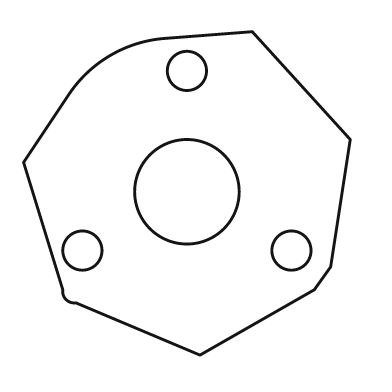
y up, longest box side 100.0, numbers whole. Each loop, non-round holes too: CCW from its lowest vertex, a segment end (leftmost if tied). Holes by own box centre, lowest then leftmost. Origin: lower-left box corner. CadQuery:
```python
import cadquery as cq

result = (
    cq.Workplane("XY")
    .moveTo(54.0, 0.0)
    .lineTo(89.0, 20.0)
    .lineTo(94.0, 27.0)
    .lineTo(100.0, 66.0)
    .lineTo(70.0, 99.0)
    .lineTo(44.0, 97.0)
    .threePointArc((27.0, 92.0), (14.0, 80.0))
    .lineTo(0.0, 59.0)
    .lineTo(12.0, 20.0)
    .threePointArc((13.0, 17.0), (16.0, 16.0))
    .close()
    .moveTo(18.0, 32.0)
    .circle(6.0)
    .moveTo(82.0, 32.0)
    .circle(6.0)
    .moveTo(50.0, 50.0)
    .circle(16.0)
    .moveTo(50.0, 87.0)
    .circle(6.0)
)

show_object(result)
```